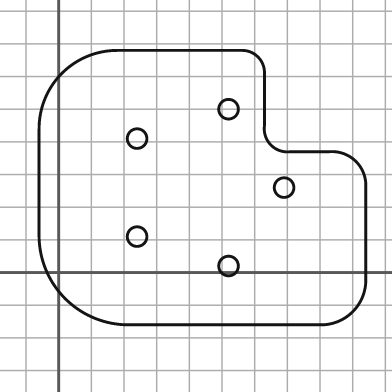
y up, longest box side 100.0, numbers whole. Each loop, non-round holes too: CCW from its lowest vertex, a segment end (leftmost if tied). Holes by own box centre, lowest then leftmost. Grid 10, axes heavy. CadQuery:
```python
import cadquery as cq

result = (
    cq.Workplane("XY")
    .moveTo(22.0, -16.0)
    .lineTo(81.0, -16.0)
    .threePointArc((90.0, -12.0), (94.0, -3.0))
    .lineTo(94.0, 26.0)
    .threePointArc((91.0, 34.0), (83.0, 37.0))
    .lineTo(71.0, 37.0)
    .threePointArc((65.0, 39.0), (63.0, 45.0))
    .lineTo(63.0, 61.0)
    .threePointArc((61.0, 66.0), (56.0, 68.0))
    .lineTo(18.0, 68.0)
    .threePointArc((1.0, 61.0), (-6.0, 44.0))
    .lineTo(-6.0, 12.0)
    .threePointArc((2.0, -8.0), (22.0, -16.0))
    .close()
    .moveTo(52.0, 2.0)
    .circle(3.0)
    .moveTo(24.0, 11.0)
    .circle(3.0)
    .moveTo(69.0, 26.0)
    .circle(3.0)
    .moveTo(24.0, 41.0)
    .circle(3.0)
    .moveTo(52.0, 50.0)
    .circle(3.0)
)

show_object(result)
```